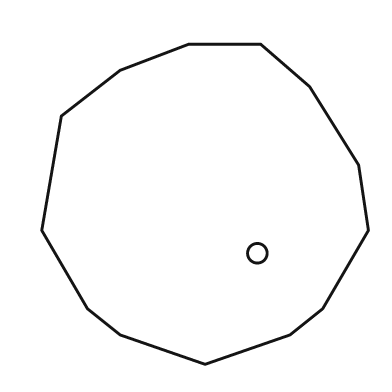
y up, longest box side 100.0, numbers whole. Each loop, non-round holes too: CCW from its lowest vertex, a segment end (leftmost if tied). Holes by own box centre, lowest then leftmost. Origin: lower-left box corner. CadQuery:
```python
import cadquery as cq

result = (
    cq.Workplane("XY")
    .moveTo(50.0, 0.0)
    .lineTo(76.0, 9.0)
    .lineTo(86.0, 17.0)
    .lineTo(100.0, 41.0)
    .lineTo(97.0, 61.0)
    .lineTo(82.0, 85.0)
    .lineTo(67.0, 98.0)
    .lineTo(45.0, 98.0)
    .lineTo(24.0, 90.0)
    .lineTo(6.0, 76.0)
    .lineTo(0.0, 41.0)
    .lineTo(14.0, 17.0)
    .lineTo(24.0, 9.0)
    .close()
    .moveTo(66.0, 34.0)
    .circle(3.0)
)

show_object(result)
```